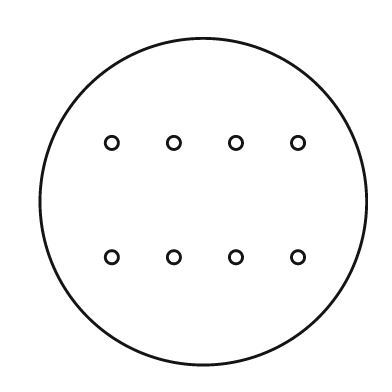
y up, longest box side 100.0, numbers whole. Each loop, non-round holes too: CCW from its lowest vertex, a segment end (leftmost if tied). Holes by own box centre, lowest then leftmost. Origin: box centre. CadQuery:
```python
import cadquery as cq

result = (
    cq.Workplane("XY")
    .moveTo(0.0, 0.0)
    .circle(50.0)
    .moveTo(-28.0, -17.0)
    .circle(2.0)
    .moveTo(-9.0, -17.0)
    .circle(2.0)
    .moveTo(10.0, -17.0)
    .circle(2.0)
    .moveTo(29.0, -17.0)
    .circle(2.0)
    .moveTo(-28.0, 18.0)
    .circle(2.0)
    .moveTo(-9.0, 18.0)
    .circle(2.0)
    .moveTo(10.0, 18.0)
    .circle(2.0)
    .moveTo(29.0, 18.0)
    .circle(2.0)
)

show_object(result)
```